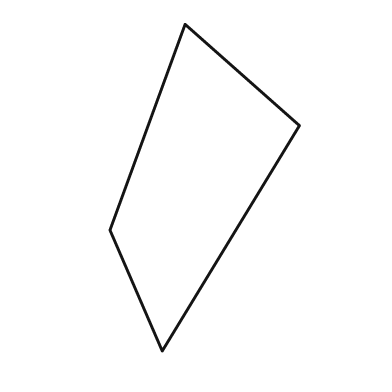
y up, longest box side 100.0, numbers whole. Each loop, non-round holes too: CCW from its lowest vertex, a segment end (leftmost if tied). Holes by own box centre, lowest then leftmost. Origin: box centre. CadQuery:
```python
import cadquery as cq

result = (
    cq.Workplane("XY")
    .moveTo(-13.0, -50.0)
    .lineTo(29.0, 19.0)
    .lineTo(-6.0, 50.0)
    .lineTo(-29.0, -13.0)
    .close()
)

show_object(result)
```